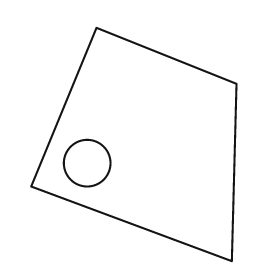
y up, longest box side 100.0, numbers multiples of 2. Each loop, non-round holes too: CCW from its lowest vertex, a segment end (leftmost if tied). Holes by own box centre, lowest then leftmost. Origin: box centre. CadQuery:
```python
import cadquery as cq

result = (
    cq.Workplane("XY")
    .moveTo(42.0, -50.0)
    .lineTo(44.0, 26.0)
    .lineTo(-16.0, 50.0)
    .lineTo(-44.0, -18.0)
    .close()
    .moveTo(-20.0, -8.0)
    .circle(10.0)
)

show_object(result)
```